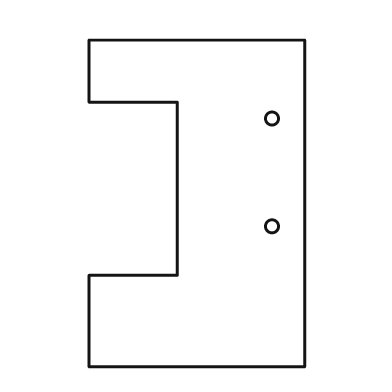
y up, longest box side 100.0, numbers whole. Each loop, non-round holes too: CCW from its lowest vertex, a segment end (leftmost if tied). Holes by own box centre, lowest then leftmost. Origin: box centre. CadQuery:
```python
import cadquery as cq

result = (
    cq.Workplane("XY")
    .moveTo(-33.0, -50.0)
    .lineTo(33.0, -50.0)
    .lineTo(33.0, 50.0)
    .lineTo(-33.0, 50.0)
    .lineTo(-33.0, 31.0)
    .lineTo(-6.0, 31.0)
    .lineTo(-6.0, -22.0)
    .lineTo(-33.0, -22.0)
    .close()
    .moveTo(23.0, -7.0)
    .circle(2.0)
    .moveTo(23.0, 26.0)
    .circle(2.0)
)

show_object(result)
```